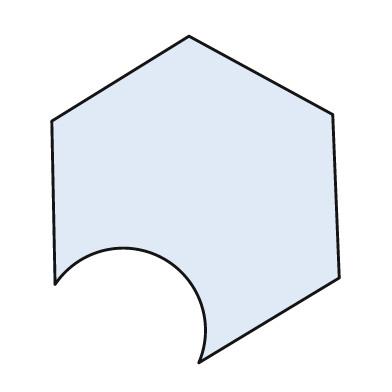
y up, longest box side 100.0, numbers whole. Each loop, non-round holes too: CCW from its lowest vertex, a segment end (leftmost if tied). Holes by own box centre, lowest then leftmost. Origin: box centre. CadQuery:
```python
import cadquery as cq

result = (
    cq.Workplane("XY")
    .moveTo(1.0, -50.0)
    .lineTo(44.0, -24.0)
    .lineTo(42.0, 26.0)
    .lineTo(-2.0, 50.0)
    .lineTo(-44.0, 24.0)
    .lineTo(-43.0, -26.0)
    .threePointArc((-10.0, -18.0), (1.0, -50.0))
    .close()
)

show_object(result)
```